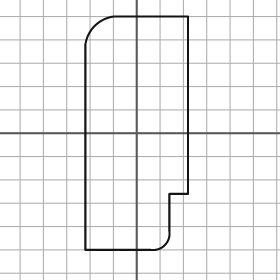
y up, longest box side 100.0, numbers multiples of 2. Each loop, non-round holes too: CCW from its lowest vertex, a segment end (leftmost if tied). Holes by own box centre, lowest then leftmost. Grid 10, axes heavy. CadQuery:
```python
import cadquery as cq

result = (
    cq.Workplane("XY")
    .moveTo(-22.0, -50.0)
    .lineTo(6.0, -50.0)
    .threePointArc((12.0, -48.0), (14.0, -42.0))
    .lineTo(14.0, -26.0)
    .lineTo(22.0, -26.0)
    .lineTo(22.0, 50.0)
    .lineTo(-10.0, 50.0)
    .threePointArc((-18.0, 46.0), (-22.0, 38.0))
    .close()
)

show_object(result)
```